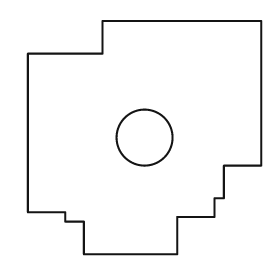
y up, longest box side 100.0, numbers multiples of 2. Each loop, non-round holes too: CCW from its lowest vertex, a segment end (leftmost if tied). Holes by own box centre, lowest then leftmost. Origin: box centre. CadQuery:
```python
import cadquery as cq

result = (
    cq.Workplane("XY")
    .moveTo(-26.0, -50.0)
    .lineTo(14.0, -50.0)
    .lineTo(14.0, -34.0)
    .lineTo(30.0, -34.0)
    .lineTo(30.0, -26.0)
    .lineTo(34.0, -26.0)
    .lineTo(34.0, -12.0)
    .lineTo(50.0, -12.0)
    .lineTo(50.0, 50.0)
    .lineTo(-18.0, 50.0)
    .lineTo(-18.0, 36.0)
    .lineTo(-50.0, 36.0)
    .lineTo(-50.0, -32.0)
    .lineTo(-34.0, -32.0)
    .lineTo(-34.0, -36.0)
    .lineTo(-26.0, -36.0)
    .close()
    .moveTo(0.0, 0.0)
    .circle(12.0)
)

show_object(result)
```